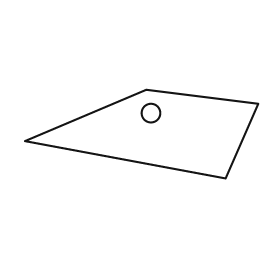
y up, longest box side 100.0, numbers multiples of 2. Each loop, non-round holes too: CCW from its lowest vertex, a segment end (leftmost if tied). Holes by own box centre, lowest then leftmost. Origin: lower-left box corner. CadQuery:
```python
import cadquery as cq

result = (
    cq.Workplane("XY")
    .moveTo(86.0, 0.0)
    .lineTo(100.0, 32.0)
    .lineTo(52.0, 38.0)
    .lineTo(0.0, 16.0)
    .close()
    .moveTo(54.0, 28.0)
    .circle(4.0)
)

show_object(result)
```